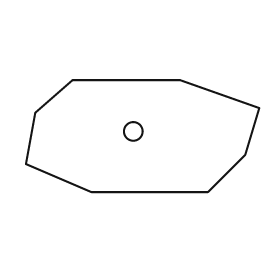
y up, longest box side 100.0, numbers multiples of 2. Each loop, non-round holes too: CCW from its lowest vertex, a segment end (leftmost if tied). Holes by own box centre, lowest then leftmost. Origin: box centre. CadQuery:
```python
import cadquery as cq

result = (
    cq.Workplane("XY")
    .moveTo(-22.0, -24.0)
    .lineTo(28.0, -24.0)
    .lineTo(44.0, -8.0)
    .lineTo(50.0, 12.0)
    .lineTo(16.0, 24.0)
    .lineTo(-30.0, 24.0)
    .lineTo(-46.0, 10.0)
    .lineTo(-50.0, -12.0)
    .close()
    .moveTo(-4.0, 2.0)
    .circle(4.0)
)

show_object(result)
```